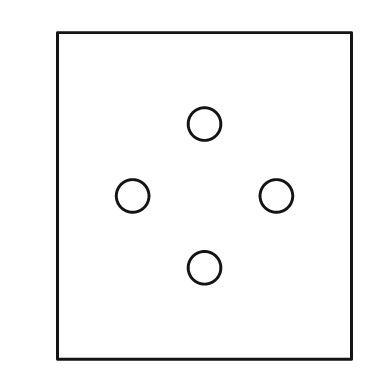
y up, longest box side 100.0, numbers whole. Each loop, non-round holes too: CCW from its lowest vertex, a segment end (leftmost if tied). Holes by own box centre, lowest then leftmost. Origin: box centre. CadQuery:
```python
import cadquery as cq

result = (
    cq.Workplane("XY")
    .moveTo(-45.0, -50.0)
    .lineTo(45.0, -50.0)
    .lineTo(45.0, 50.0)
    .lineTo(-45.0, 50.0)
    .close()
    .moveTo(0.0, -22.0)
    .circle(5.0)
    .moveTo(-22.0, 0.0)
    .circle(5.0)
    .moveTo(22.0, 0.0)
    .circle(5.0)
    .moveTo(0.0, 22.0)
    .circle(5.0)
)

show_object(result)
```